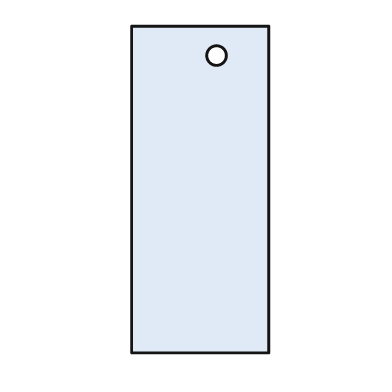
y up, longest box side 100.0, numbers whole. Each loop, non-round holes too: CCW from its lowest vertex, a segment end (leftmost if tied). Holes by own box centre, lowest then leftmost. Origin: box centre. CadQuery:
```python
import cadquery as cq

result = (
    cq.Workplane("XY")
    .moveTo(-21.0, -50.0)
    .lineTo(21.0, -50.0)
    .lineTo(21.0, 50.0)
    .lineTo(-21.0, 50.0)
    .close()
    .moveTo(5.0, 41.0)
    .circle(3.0)
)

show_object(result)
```